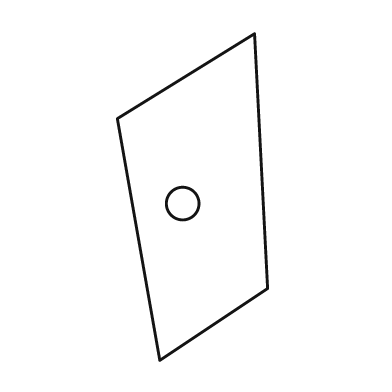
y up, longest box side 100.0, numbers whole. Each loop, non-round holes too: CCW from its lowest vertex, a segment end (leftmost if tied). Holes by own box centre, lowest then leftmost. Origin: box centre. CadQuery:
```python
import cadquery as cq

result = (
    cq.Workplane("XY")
    .moveTo(-10.0, -50.0)
    .lineTo(23.0, -28.0)
    .lineTo(19.0, 50.0)
    .lineTo(-23.0, 24.0)
    .close()
    .moveTo(-3.0, -2.0)
    .circle(5.0)
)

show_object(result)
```